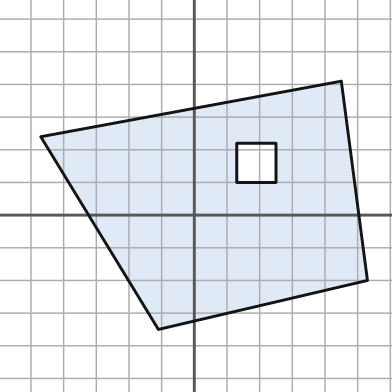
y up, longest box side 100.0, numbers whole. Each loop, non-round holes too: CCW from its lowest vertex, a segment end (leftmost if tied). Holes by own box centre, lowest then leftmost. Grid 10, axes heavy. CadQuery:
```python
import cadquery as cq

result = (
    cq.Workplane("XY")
    .moveTo(-11.0, -35.0)
    .lineTo(53.0, -20.0)
    .lineTo(45.0, 41.0)
    .lineTo(-47.0, 24.0)
    .close()
    .moveTo(13.0, 10.0)
    .lineTo(25.0, 10.0)
    .lineTo(25.0, 22.0)
    .lineTo(13.0, 22.0)
    .close()
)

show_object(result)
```